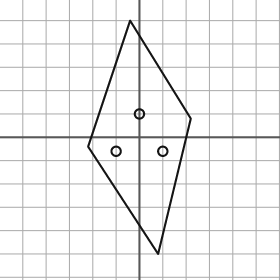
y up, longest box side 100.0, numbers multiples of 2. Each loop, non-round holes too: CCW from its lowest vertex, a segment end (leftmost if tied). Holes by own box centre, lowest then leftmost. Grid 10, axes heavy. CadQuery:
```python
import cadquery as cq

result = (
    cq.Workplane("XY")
    .moveTo(8.0, -50.0)
    .lineTo(22.0, 8.0)
    .lineTo(-4.0, 50.0)
    .lineTo(-22.0, -4.0)
    .close()
    .moveTo(-10.0, -6.0)
    .circle(2.0)
    .moveTo(10.0, -6.0)
    .circle(2.0)
    .moveTo(0.0, 10.0)
    .circle(2.0)
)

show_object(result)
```